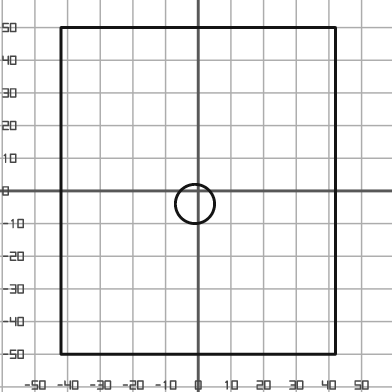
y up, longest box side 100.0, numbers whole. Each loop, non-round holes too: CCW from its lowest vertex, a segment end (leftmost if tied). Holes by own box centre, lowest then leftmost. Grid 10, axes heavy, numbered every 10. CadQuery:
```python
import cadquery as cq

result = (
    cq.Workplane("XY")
    .moveTo(-42.0, -50.0)
    .lineTo(42.0, -50.0)
    .lineTo(42.0, 50.0)
    .lineTo(-42.0, 50.0)
    .close()
    .moveTo(-1.0, -4.0)
    .circle(6.0)
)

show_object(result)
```